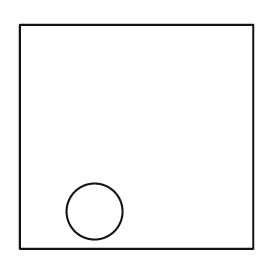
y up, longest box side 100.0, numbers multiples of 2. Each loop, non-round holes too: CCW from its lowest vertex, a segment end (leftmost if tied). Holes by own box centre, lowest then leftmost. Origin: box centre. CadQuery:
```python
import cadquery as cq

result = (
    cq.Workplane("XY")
    .moveTo(-50.0, -48.0)
    .lineTo(50.0, -48.0)
    .lineTo(50.0, 48.0)
    .lineTo(-50.0, 48.0)
    .close()
    .moveTo(-18.0, -32.0)
    .circle(12.0)
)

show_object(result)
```